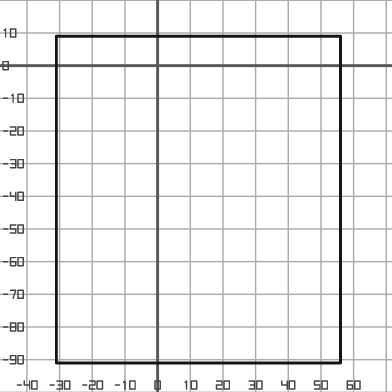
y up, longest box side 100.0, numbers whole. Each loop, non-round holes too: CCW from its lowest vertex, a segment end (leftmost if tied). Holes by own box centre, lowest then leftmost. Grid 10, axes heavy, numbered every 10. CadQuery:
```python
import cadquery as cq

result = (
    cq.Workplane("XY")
    .moveTo(-31.0, -91.0)
    .lineTo(56.0, -91.0)
    .lineTo(56.0, 9.0)
    .lineTo(-31.0, 9.0)
    .close()
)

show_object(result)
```